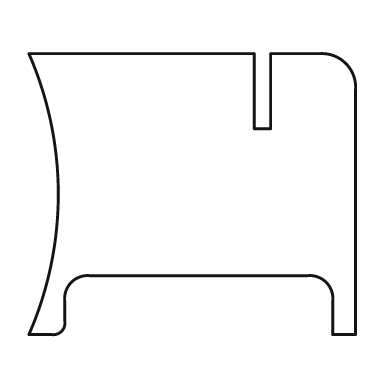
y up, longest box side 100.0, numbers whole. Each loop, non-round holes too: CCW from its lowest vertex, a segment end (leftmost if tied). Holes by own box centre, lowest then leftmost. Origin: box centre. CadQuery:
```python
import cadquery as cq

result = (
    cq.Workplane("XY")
    .moveTo(-50.0, -43.0)
    .lineTo(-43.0, -43.0)
    .threePointArc((-40.0, -42.0), (-39.0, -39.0))
    .lineTo(-39.0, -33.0)
    .threePointArc((-37.0, -27.0), (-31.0, -25.0))
    .lineTo(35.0, -25.0)
    .threePointArc((41.0, -27.0), (43.0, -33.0))
    .lineTo(43.0, -43.0)
    .lineTo(50.0, -43.0)
    .lineTo(50.0, 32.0)
    .threePointArc((47.0, 40.0), (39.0, 43.0))
    .lineTo(24.0, 43.0)
    .lineTo(24.0, 20.0)
    .lineTo(19.0, 20.0)
    .lineTo(19.0, 43.0)
    .lineTo(-50.0, 43.0)
    .threePointArc((-41.0, 0.0), (-50.0, -43.0))
    .close()
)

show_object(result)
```